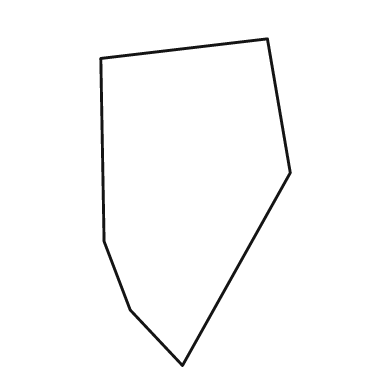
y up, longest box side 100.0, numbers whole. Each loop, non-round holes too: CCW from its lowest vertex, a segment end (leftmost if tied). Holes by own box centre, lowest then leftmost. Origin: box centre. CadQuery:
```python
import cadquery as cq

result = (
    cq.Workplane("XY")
    .moveTo(-4.0, -50.0)
    .lineTo(29.0, 9.0)
    .lineTo(22.0, 50.0)
    .lineTo(-29.0, 44.0)
    .lineTo(-28.0, -12.0)
    .lineTo(-20.0, -33.0)
    .close()
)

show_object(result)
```